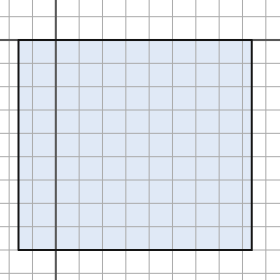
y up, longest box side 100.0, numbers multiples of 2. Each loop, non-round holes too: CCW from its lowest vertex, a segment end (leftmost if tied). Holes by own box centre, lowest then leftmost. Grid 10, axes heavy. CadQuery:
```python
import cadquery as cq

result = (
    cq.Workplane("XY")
    .moveTo(-16.0, -90.0)
    .lineTo(84.0, -90.0)
    .lineTo(84.0, 0.0)
    .lineTo(-16.0, 0.0)
    .close()
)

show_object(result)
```